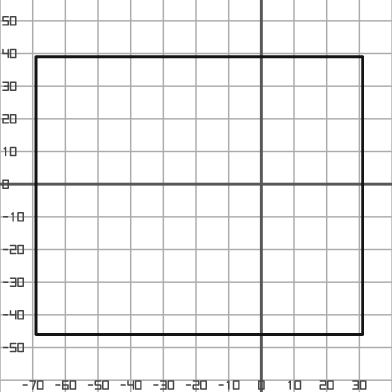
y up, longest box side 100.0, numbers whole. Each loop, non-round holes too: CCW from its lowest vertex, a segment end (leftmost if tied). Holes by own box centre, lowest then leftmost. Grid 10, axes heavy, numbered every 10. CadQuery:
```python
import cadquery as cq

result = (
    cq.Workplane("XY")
    .moveTo(-69.0, -46.0)
    .lineTo(31.0, -46.0)
    .lineTo(31.0, 39.0)
    .lineTo(-69.0, 39.0)
    .close()
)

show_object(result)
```